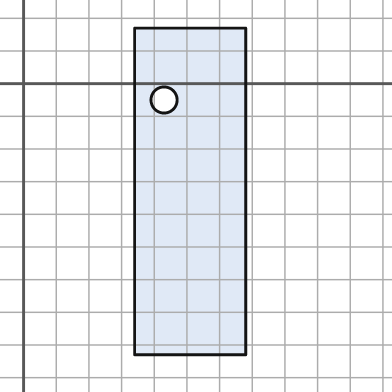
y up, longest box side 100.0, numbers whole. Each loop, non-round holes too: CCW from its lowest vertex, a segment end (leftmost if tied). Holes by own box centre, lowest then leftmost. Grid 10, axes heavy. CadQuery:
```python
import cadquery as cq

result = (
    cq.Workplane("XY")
    .moveTo(34.0, -83.0)
    .lineTo(68.0, -83.0)
    .lineTo(68.0, 17.0)
    .lineTo(34.0, 17.0)
    .close()
    .moveTo(43.0, -5.0)
    .circle(4.0)
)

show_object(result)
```